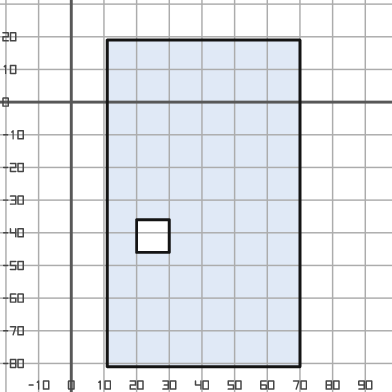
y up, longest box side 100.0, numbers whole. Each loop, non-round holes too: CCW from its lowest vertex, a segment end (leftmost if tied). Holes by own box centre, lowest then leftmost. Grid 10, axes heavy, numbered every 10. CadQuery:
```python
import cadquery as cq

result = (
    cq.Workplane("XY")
    .moveTo(11.0, -81.0)
    .lineTo(70.0, -81.0)
    .lineTo(70.0, 19.0)
    .lineTo(11.0, 19.0)
    .close()
    .moveTo(20.0, -46.0)
    .lineTo(30.0, -46.0)
    .lineTo(30.0, -36.0)
    .lineTo(20.0, -36.0)
    .close()
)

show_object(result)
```